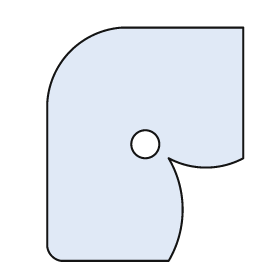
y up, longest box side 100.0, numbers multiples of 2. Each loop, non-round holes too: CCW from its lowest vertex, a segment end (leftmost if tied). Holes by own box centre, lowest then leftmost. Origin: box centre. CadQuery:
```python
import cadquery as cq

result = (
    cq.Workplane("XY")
    .moveTo(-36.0, -50.0)
    .lineTo(10.0, -50.0)
    .threePointArc((16.0, -28.0), (10.0, -6.0))
    .threePointArc((26.0, -10.0), (42.0, -6.0))
    .lineTo(42.0, 50.0)
    .lineTo(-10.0, 50.0)
    .threePointArc((-32.0, 40.0), (-42.0, 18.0))
    .lineTo(-42.0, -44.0)
    .threePointArc((-40.0, -48.0), (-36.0, -50.0))
    .close()
    .moveTo(0.0, 0.0)
    .circle(6.0)
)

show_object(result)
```